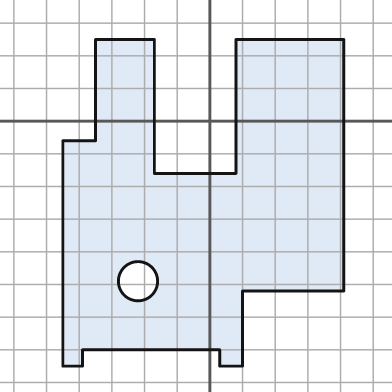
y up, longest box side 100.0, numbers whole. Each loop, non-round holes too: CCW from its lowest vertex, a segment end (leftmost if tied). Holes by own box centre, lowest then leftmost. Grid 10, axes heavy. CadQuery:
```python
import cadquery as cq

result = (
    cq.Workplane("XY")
    .moveTo(-45.0, -75.0)
    .lineTo(-39.0, -75.0)
    .lineTo(-39.0, -70.0)
    .lineTo(3.0, -70.0)
    .lineTo(3.0, -75.0)
    .lineTo(10.0, -75.0)
    .lineTo(10.0, -52.0)
    .lineTo(41.0, -52.0)
    .lineTo(41.0, 25.0)
    .lineTo(8.0, 25.0)
    .lineTo(8.0, -16.0)
    .lineTo(-17.0, -16.0)
    .lineTo(-17.0, 25.0)
    .lineTo(-35.0, 25.0)
    .lineTo(-35.0, -6.0)
    .lineTo(-45.0, -6.0)
    .close()
    .moveTo(-22.0, -49.0)
    .circle(6.0)
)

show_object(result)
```